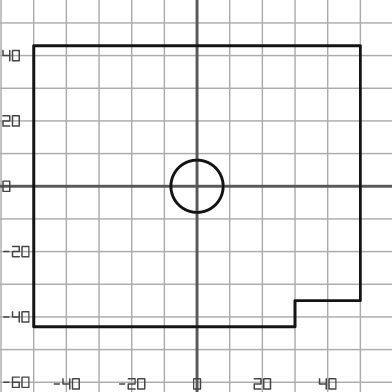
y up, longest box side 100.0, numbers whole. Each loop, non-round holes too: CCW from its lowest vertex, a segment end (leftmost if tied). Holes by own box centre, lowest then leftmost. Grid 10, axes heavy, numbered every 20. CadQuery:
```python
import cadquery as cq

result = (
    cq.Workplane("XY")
    .moveTo(-50.0, -43.0)
    .lineTo(30.0, -43.0)
    .lineTo(30.0, -35.0)
    .lineTo(50.0, -35.0)
    .lineTo(50.0, 43.0)
    .lineTo(-50.0, 43.0)
    .close()
    .moveTo(0.0, 0.0)
    .circle(8.0)
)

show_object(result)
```